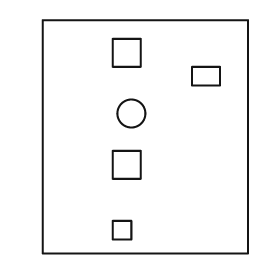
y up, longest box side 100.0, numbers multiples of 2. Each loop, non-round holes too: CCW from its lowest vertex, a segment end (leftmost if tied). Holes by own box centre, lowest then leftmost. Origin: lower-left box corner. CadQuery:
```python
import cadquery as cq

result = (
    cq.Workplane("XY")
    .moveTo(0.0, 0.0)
    .lineTo(88.0, 0.0)
    .lineTo(88.0, 100.0)
    .lineTo(0.0, 100.0)
    .close()
    .moveTo(30.0, 6.0)
    .lineTo(38.0, 6.0)
    .lineTo(38.0, 14.0)
    .lineTo(30.0, 14.0)
    .close()
    .moveTo(30.0, 32.0)
    .lineTo(42.0, 32.0)
    .lineTo(42.0, 44.0)
    .lineTo(30.0, 44.0)
    .close()
    .moveTo(38.0, 60.0)
    .circle(6.0)
    .moveTo(64.0, 72.0)
    .lineTo(76.0, 72.0)
    .lineTo(76.0, 80.0)
    .lineTo(64.0, 80.0)
    .close()
    .moveTo(30.0, 80.0)
    .lineTo(42.0, 80.0)
    .lineTo(42.0, 92.0)
    .lineTo(30.0, 92.0)
    .close()
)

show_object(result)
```